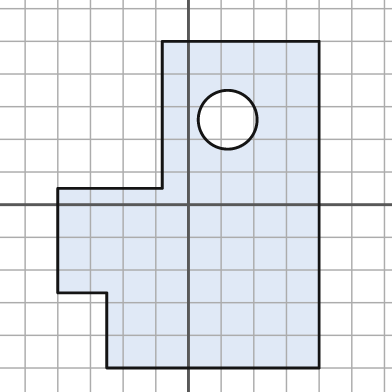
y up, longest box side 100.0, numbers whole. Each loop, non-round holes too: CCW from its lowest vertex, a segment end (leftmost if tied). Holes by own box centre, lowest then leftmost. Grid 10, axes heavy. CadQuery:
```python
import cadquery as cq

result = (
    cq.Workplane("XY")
    .moveTo(-25.0, -50.0)
    .lineTo(40.0, -50.0)
    .lineTo(40.0, 50.0)
    .lineTo(-8.0, 50.0)
    .lineTo(-8.0, 5.0)
    .lineTo(-40.0, 5.0)
    .lineTo(-40.0, -27.0)
    .lineTo(-25.0, -27.0)
    .close()
    .moveTo(12.0, 26.0)
    .circle(9.0)
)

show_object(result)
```